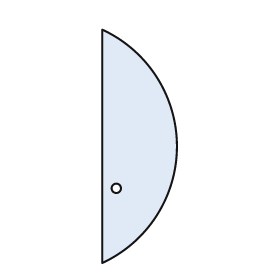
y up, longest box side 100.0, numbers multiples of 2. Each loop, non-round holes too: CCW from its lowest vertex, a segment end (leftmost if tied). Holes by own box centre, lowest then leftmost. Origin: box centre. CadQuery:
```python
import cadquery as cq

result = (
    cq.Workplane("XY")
    .moveTo(-16.0, -50.0)
    .threePointArc((16.0, 0.0), (-16.0, 50.0))
    .close()
    .moveTo(-10.0, -18.0)
    .circle(2.0)
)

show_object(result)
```